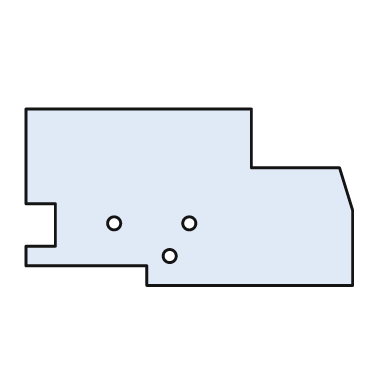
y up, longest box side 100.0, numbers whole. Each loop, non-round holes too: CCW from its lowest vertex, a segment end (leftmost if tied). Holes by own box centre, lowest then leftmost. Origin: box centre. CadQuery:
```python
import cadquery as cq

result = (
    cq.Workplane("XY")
    .moveTo(-13.0, -27.0)
    .lineTo(50.0, -27.0)
    .lineTo(50.0, -4.0)
    .lineTo(46.0, 9.0)
    .lineTo(19.0, 9.0)
    .lineTo(19.0, 27.0)
    .lineTo(-50.0, 27.0)
    .lineTo(-50.0, -2.0)
    .lineTo(-41.0, -2.0)
    .lineTo(-41.0, -15.0)
    .lineTo(-50.0, -15.0)
    .lineTo(-50.0, -21.0)
    .lineTo(-13.0, -21.0)
    .close()
    .moveTo(-6.0, -18.0)
    .circle(2.0)
    .moveTo(-23.0, -8.0)
    .circle(2.0)
    .moveTo(0.0, -8.0)
    .circle(2.0)
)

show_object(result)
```